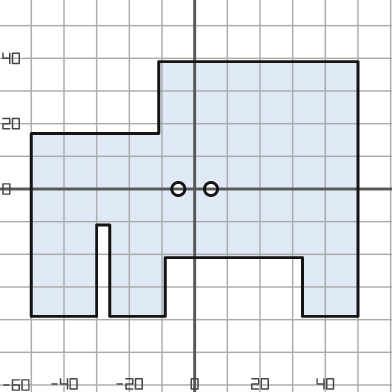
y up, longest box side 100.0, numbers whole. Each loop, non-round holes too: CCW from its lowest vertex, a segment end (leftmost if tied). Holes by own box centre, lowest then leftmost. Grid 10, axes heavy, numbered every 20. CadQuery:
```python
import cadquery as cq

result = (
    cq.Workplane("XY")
    .moveTo(-50.0, -39.0)
    .lineTo(-30.0, -39.0)
    .lineTo(-30.0, -11.0)
    .lineTo(-26.0, -11.0)
    .lineTo(-26.0, -39.0)
    .lineTo(-9.0, -39.0)
    .lineTo(-9.0, -21.0)
    .lineTo(33.0, -21.0)
    .lineTo(33.0, -39.0)
    .lineTo(50.0, -39.0)
    .lineTo(50.0, 39.0)
    .lineTo(-11.0, 39.0)
    .lineTo(-11.0, 17.0)
    .lineTo(-50.0, 17.0)
    .close()
    .moveTo(-5.0, 0.0)
    .circle(2.0)
    .moveTo(5.0, 0.0)
    .circle(2.0)
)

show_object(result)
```